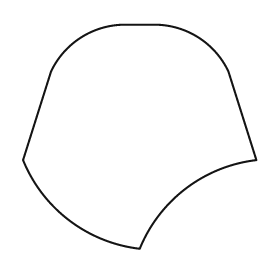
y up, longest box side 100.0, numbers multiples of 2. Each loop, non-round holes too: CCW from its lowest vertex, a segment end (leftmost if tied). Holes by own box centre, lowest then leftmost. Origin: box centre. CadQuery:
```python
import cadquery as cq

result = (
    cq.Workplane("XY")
    .moveTo(0.0, -48.0)
    .threePointArc((20.0, -22.0), (50.0, -10.0))
    .lineTo(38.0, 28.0)
    .threePointArc((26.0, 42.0), (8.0, 48.0))
    .lineTo(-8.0, 48.0)
    .threePointArc((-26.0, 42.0), (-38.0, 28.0))
    .lineTo(-50.0, -10.0)
    .threePointArc((-30.0, -36.0), (0.0, -48.0))
    .close()
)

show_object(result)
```